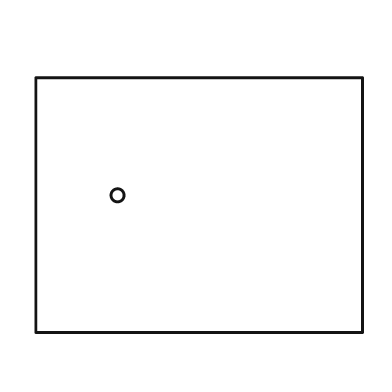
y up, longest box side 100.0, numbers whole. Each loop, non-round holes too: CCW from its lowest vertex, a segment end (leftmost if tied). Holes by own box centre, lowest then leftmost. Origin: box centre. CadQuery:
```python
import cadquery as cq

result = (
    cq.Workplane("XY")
    .moveTo(-50.0, -39.0)
    .lineTo(50.0, -39.0)
    .lineTo(50.0, 39.0)
    .lineTo(-50.0, 39.0)
    .close()
    .moveTo(-25.0, 3.0)
    .circle(2.0)
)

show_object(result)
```